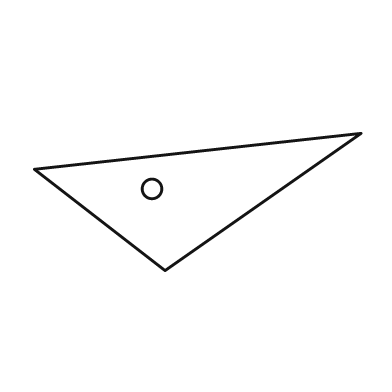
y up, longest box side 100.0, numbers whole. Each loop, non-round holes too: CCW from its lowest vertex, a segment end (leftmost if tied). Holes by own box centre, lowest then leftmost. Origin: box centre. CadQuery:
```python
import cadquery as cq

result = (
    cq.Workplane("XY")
    .moveTo(-10.0, -21.0)
    .lineTo(50.0, 21.0)
    .lineTo(-50.0, 10.0)
    .close()
    .moveTo(-14.0, 4.0)
    .circle(3.0)
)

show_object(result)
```